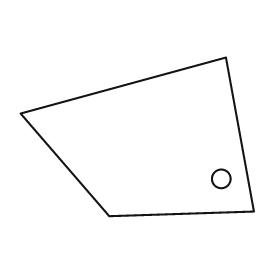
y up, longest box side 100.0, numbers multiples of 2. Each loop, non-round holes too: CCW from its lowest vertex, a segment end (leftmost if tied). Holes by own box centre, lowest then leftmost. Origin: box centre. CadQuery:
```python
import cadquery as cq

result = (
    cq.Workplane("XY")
    .moveTo(-12.0, -34.0)
    .lineTo(50.0, -32.0)
    .lineTo(38.0, 34.0)
    .lineTo(-50.0, 10.0)
    .close()
    .moveTo(36.0, -18.0)
    .circle(4.0)
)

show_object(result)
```